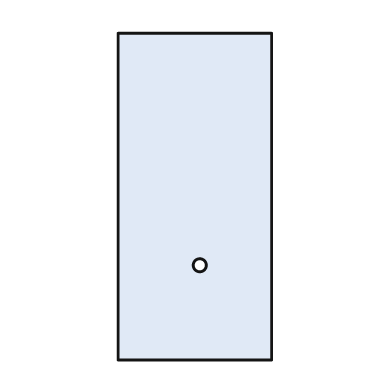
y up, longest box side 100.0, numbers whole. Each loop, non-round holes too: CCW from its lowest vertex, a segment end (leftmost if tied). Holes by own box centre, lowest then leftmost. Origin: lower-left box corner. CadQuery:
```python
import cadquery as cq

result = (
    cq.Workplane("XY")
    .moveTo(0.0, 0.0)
    .lineTo(47.0, 0.0)
    .lineTo(47.0, 100.0)
    .lineTo(0.0, 100.0)
    .close()
    .moveTo(25.0, 29.0)
    .circle(2.0)
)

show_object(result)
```